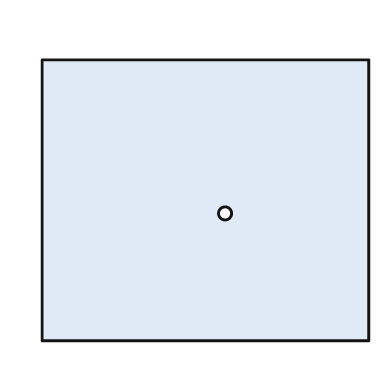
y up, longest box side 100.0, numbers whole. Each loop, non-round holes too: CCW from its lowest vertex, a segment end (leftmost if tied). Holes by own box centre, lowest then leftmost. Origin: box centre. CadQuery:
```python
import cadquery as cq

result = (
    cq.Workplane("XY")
    .moveTo(-50.0, -43.0)
    .lineTo(50.0, -43.0)
    .lineTo(50.0, 43.0)
    .lineTo(-50.0, 43.0)
    .close()
    .moveTo(6.0, -4.0)
    .circle(2.0)
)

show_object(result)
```